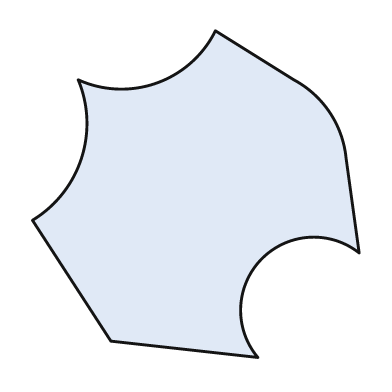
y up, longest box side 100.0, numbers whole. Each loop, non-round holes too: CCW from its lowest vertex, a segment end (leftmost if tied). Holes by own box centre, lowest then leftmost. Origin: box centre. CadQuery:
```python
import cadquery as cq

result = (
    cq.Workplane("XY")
    .moveTo(19.0, -50.0)
    .threePointArc((20.0, -20.0), (50.0, -18.0))
    .lineTo(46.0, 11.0)
    .threePointArc((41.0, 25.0), (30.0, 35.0))
    .lineTo(6.0, 50.0)
    .threePointArc((-12.0, 34.0), (-36.0, 35.0))
    .threePointArc((-35.0, 11.0), (-50.0, -8.0))
    .lineTo(-26.0, -45.0)
    .close()
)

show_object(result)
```